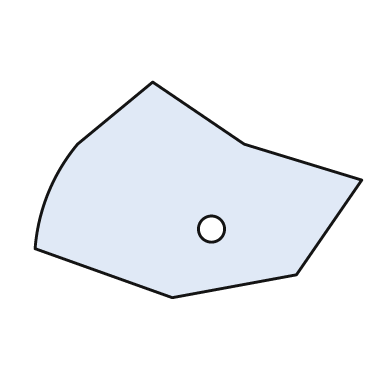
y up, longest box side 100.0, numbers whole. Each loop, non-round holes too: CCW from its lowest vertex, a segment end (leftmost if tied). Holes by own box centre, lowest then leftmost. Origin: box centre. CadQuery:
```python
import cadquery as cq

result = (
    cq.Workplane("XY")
    .moveTo(-8.0, -33.0)
    .lineTo(30.0, -26.0)
    .lineTo(50.0, 3.0)
    .lineTo(14.0, 14.0)
    .lineTo(-14.0, 33.0)
    .lineTo(-37.0, 14.0)
    .threePointArc((-46.0, -1.0), (-50.0, -18.0))
    .close()
    .moveTo(4.0, -12.0)
    .circle(4.0)
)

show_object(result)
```